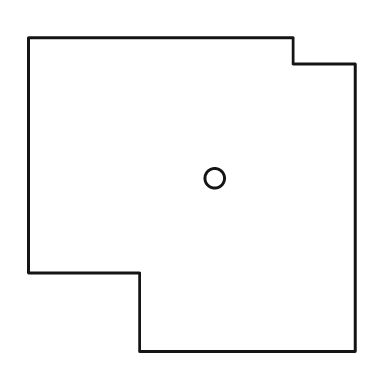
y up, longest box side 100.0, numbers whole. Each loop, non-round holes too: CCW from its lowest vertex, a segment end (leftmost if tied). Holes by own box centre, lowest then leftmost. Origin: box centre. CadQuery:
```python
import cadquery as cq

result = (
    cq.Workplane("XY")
    .moveTo(-16.0, -48.0)
    .lineTo(50.0, -48.0)
    .lineTo(50.0, 40.0)
    .lineTo(31.0, 40.0)
    .lineTo(31.0, 48.0)
    .lineTo(-50.0, 48.0)
    .lineTo(-50.0, -24.0)
    .lineTo(-16.0, -24.0)
    .close()
    .moveTo(7.0, 5.0)
    .circle(3.0)
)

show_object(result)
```